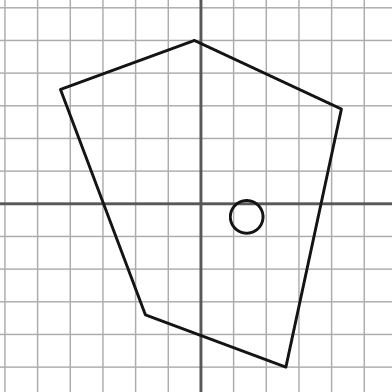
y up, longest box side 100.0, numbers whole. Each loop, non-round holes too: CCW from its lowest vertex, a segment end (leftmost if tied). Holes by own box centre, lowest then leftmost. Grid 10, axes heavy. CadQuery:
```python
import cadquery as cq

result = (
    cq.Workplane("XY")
    .moveTo(26.0, -50.0)
    .lineTo(43.0, 29.0)
    .lineTo(-2.0, 50.0)
    .lineTo(-43.0, 35.0)
    .lineTo(-17.0, -34.0)
    .close()
    .moveTo(14.0, -4.0)
    .circle(5.0)
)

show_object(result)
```